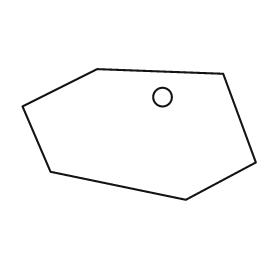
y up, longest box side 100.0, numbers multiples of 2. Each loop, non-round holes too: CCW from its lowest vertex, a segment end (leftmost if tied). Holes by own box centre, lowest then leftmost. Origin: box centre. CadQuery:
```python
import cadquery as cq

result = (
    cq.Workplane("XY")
    .moveTo(20.0, -28.0)
    .lineTo(50.0, -12.0)
    .lineTo(36.0, 26.0)
    .lineTo(-18.0, 28.0)
    .lineTo(-50.0, 12.0)
    .lineTo(-38.0, -16.0)
    .close()
    .moveTo(10.0, 16.0)
    .circle(4.0)
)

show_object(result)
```